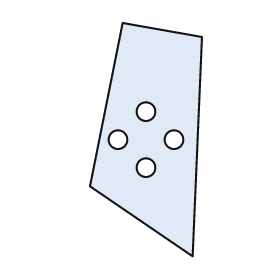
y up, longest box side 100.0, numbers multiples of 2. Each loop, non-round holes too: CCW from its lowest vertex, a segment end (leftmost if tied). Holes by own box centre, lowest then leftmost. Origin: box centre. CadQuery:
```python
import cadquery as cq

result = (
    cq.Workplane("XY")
    .moveTo(20.0, -50.0)
    .lineTo(24.0, 44.0)
    .lineTo(-10.0, 50.0)
    .lineTo(-24.0, -20.0)
    .close()
    .moveTo(0.0, -12.0)
    .circle(4.0)
    .moveTo(-12.0, 0.0)
    .circle(4.0)
    .moveTo(12.0, 0.0)
    .circle(4.0)
    .moveTo(0.0, 12.0)
    .circle(4.0)
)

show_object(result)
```